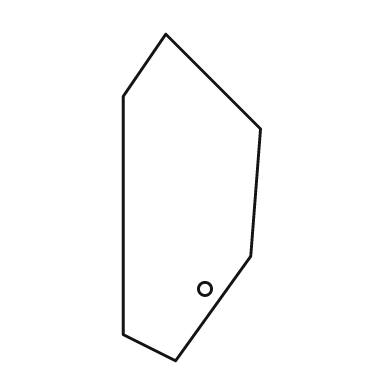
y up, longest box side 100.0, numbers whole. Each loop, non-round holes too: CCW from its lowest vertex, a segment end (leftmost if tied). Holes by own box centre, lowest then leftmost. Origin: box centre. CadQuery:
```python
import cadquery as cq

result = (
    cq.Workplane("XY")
    .moveTo(-5.0, -50.0)
    .lineTo(18.0, -18.0)
    .lineTo(21.0, 21.0)
    .lineTo(-8.0, 50.0)
    .lineTo(-21.0, 31.0)
    .lineTo(-21.0, -42.0)
    .close()
    .moveTo(4.0, -28.0)
    .circle(2.0)
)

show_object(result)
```